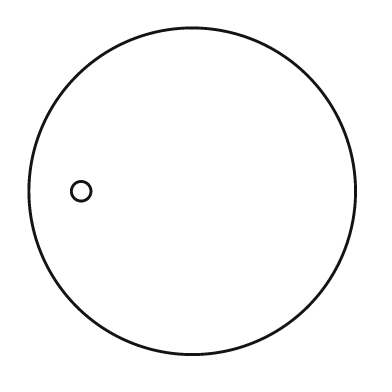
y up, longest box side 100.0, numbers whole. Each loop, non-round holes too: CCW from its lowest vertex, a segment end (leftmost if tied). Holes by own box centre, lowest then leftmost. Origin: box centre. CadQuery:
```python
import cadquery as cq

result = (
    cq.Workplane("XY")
    .moveTo(0.0, 0.0)
    .circle(50.0)
    .moveTo(-34.0, 0.0)
    .circle(3.0)
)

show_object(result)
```